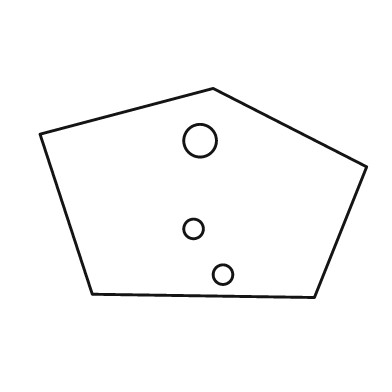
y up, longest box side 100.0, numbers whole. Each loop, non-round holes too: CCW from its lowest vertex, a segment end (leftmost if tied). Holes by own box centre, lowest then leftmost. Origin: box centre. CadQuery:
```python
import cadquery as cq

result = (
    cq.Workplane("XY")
    .moveTo(34.0, -32.0)
    .lineTo(50.0, 8.0)
    .lineTo(3.0, 32.0)
    .lineTo(-50.0, 18.0)
    .lineTo(-34.0, -31.0)
    .close()
    .moveTo(6.0, -25.0)
    .circle(3.0)
    .moveTo(-3.0, -11.0)
    .circle(3.0)
    .moveTo(-1.0, 16.0)
    .circle(5.0)
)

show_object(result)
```